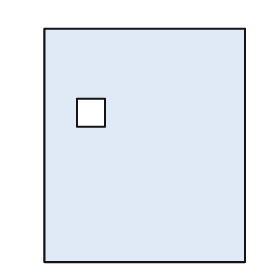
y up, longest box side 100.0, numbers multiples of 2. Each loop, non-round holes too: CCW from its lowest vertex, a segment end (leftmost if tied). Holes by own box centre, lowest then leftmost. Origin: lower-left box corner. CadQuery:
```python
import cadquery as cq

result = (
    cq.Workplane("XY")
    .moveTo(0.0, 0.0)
    .lineTo(86.0, 0.0)
    .lineTo(86.0, 100.0)
    .lineTo(0.0, 100.0)
    .close()
    .moveTo(14.0, 58.0)
    .lineTo(26.0, 58.0)
    .lineTo(26.0, 70.0)
    .lineTo(14.0, 70.0)
    .close()
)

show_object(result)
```